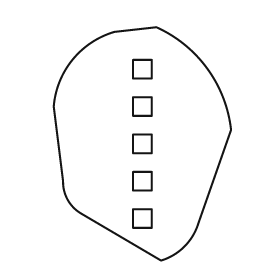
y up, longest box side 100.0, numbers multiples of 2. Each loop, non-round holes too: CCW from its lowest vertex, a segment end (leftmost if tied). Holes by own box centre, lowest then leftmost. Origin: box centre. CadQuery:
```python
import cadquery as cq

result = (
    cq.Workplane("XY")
    .moveTo(8.0, -50.0)
    .threePointArc((18.0, -44.0), (24.0, -34.0))
    .lineTo(38.0, 6.0)
    .threePointArc((28.0, 32.0), (6.0, 50.0))
    .lineTo(-12.0, 48.0)
    .threePointArc((-30.0, 36.0), (-38.0, 16.0))
    .lineTo(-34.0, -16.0)
    .threePointArc((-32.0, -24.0), (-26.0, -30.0))
    .close()
    .moveTo(-4.0, -36.0)
    .lineTo(4.0, -36.0)
    .lineTo(4.0, -28.0)
    .lineTo(-4.0, -28.0)
    .close()
    .moveTo(-4.0, -20.0)
    .lineTo(4.0, -20.0)
    .lineTo(4.0, -12.0)
    .lineTo(-4.0, -12.0)
    .close()
    .moveTo(-4.0, -4.0)
    .lineTo(4.0, -4.0)
    .lineTo(4.0, 4.0)
    .lineTo(-4.0, 4.0)
    .close()
    .moveTo(-4.0, 12.0)
    .lineTo(4.0, 12.0)
    .lineTo(4.0, 20.0)
    .lineTo(-4.0, 20.0)
    .close()
    .moveTo(-4.0, 28.0)
    .lineTo(4.0, 28.0)
    .lineTo(4.0, 36.0)
    .lineTo(-4.0, 36.0)
    .close()
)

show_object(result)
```